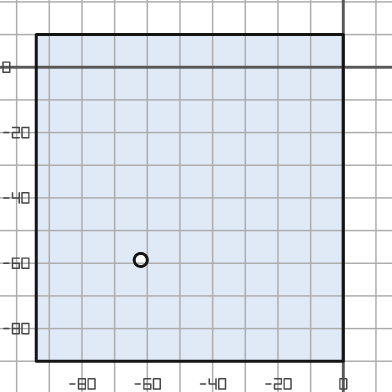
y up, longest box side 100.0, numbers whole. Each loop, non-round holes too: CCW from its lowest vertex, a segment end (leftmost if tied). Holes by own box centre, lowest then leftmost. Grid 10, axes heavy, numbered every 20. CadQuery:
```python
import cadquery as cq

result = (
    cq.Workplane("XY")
    .moveTo(-94.0, -90.0)
    .lineTo(0.0, -90.0)
    .lineTo(0.0, 10.0)
    .lineTo(-94.0, 10.0)
    .close()
    .moveTo(-62.0, -59.0)
    .circle(2.0)
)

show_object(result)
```